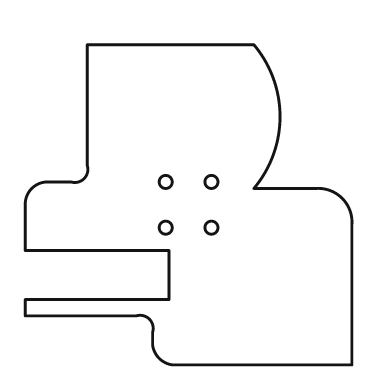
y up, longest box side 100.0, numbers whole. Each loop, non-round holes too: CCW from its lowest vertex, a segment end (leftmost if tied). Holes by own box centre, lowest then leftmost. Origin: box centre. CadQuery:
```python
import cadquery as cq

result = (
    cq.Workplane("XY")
    .moveTo(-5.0, -49.0)
    .lineTo(50.0, -49.0)
    .lineTo(50.0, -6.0)
    .threePointArc((47.0, 2.0), (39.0, 5.0))
    .lineTo(20.0, 5.0)
    .threePointArc((28.0, 27.0), (20.0, 49.0))
    .lineTo(-31.0, 49.0)
    .lineTo(-31.0, 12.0)
    .threePointArc((-32.0, 8.0), (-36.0, 7.0))
    .lineTo(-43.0, 7.0)
    .threePointArc((-48.0, 5.0), (-50.0, 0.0))
    .lineTo(-50.0, -14.0)
    .lineTo(-6.0, -14.0)
    .lineTo(-6.0, -29.0)
    .lineTo(-50.0, -29.0)
    .lineTo(-50.0, -34.0)
    .lineTo(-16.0, -34.0)
    .threePointArc((-12.0, -35.0), (-11.0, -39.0))
    .lineTo(-11.0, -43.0)
    .threePointArc((-9.0, -47.0), (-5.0, -49.0))
    .close()
    .moveTo(-7.0, -7.0)
    .circle(2.0)
    .moveTo(7.0, -7.0)
    .circle(2.0)
    .moveTo(-7.0, 7.0)
    .circle(2.0)
    .moveTo(7.0, 7.0)
    .circle(2.0)
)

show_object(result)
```